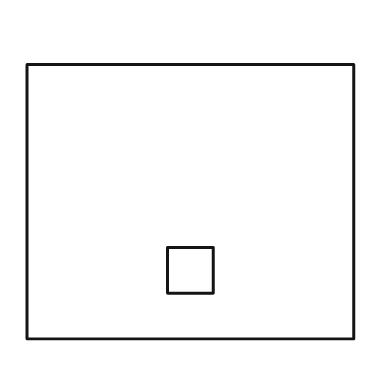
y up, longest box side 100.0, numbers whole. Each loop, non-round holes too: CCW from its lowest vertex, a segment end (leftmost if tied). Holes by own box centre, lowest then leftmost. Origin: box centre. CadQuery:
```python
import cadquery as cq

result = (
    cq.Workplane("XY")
    .moveTo(-50.0, -42.0)
    .lineTo(50.0, -42.0)
    .lineTo(50.0, 42.0)
    .lineTo(-50.0, 42.0)
    .close()
    .moveTo(-7.0, -28.0)
    .lineTo(7.0, -28.0)
    .lineTo(7.0, -14.0)
    .lineTo(-7.0, -14.0)
    .close()
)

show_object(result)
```